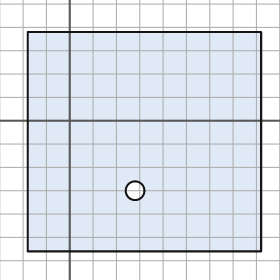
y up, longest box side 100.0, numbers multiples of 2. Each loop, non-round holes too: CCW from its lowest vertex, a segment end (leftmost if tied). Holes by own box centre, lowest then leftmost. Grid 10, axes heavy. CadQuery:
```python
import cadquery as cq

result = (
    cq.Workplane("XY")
    .moveTo(-18.0, -56.0)
    .lineTo(82.0, -56.0)
    .lineTo(82.0, 38.0)
    .lineTo(-18.0, 38.0)
    .close()
    .moveTo(28.0, -30.0)
    .circle(4.0)
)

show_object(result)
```